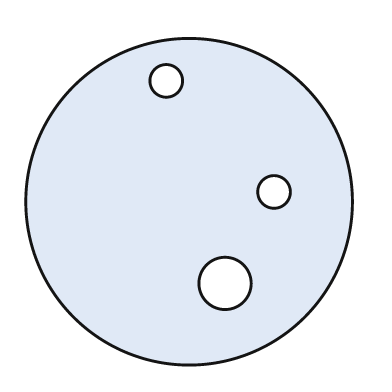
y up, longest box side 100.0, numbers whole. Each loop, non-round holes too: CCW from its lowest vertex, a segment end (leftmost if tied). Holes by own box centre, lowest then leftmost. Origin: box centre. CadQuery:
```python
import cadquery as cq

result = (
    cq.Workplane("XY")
    .moveTo(0.0, 0.0)
    .circle(50.0)
    .moveTo(11.0, -25.0)
    .circle(8.0)
    .moveTo(26.0, 3.0)
    .circle(5.0)
    .moveTo(-7.0, 37.0)
    .circle(5.0)
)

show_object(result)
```